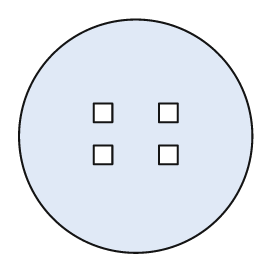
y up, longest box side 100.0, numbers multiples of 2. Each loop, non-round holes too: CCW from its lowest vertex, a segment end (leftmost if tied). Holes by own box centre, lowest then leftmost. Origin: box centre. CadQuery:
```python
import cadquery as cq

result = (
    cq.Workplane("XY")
    .moveTo(0.0, 0.0)
    .circle(50.0)
    .moveTo(-18.0, -12.0)
    .lineTo(-10.0, -12.0)
    .lineTo(-10.0, -4.0)
    .lineTo(-18.0, -4.0)
    .close()
    .moveTo(10.0, -12.0)
    .lineTo(18.0, -12.0)
    .lineTo(18.0, -4.0)
    .lineTo(10.0, -4.0)
    .close()
    .moveTo(-18.0, 6.0)
    .lineTo(-10.0, 6.0)
    .lineTo(-10.0, 14.0)
    .lineTo(-18.0, 14.0)
    .close()
    .moveTo(10.0, 6.0)
    .lineTo(18.0, 6.0)
    .lineTo(18.0, 14.0)
    .lineTo(10.0, 14.0)
    .close()
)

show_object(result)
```